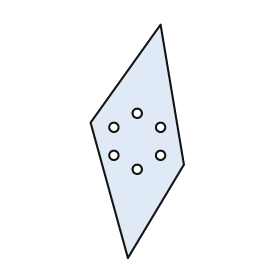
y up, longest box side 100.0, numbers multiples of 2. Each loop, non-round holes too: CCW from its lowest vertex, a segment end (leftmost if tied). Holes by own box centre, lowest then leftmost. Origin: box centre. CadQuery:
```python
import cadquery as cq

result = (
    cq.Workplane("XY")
    .moveTo(-4.0, -50.0)
    .lineTo(20.0, -10.0)
    .lineTo(10.0, 50.0)
    .lineTo(-20.0, 8.0)
    .close()
    .moveTo(0.0, -12.0)
    .circle(2.0)
    .moveTo(-10.0, -6.0)
    .circle(2.0)
    .moveTo(10.0, -6.0)
    .circle(2.0)
    .moveTo(-10.0, 6.0)
    .circle(2.0)
    .moveTo(10.0, 6.0)
    .circle(2.0)
    .moveTo(0.0, 12.0)
    .circle(2.0)
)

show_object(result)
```